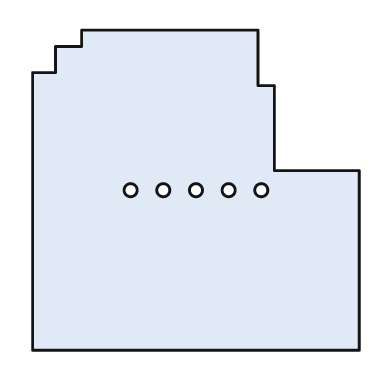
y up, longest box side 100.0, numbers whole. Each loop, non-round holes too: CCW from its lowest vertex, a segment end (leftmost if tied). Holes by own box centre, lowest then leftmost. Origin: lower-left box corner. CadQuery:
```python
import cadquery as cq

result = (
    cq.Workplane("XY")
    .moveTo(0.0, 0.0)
    .lineTo(100.0, 0.0)
    .lineTo(100.0, 55.0)
    .lineTo(74.0, 55.0)
    .lineTo(74.0, 81.0)
    .lineTo(69.0, 81.0)
    .lineTo(69.0, 98.0)
    .lineTo(15.0, 98.0)
    .lineTo(15.0, 93.0)
    .lineTo(7.0, 93.0)
    .lineTo(7.0, 85.0)
    .lineTo(0.0, 85.0)
    .close()
    .moveTo(30.0, 49.0)
    .circle(2.0)
    .moveTo(40.0, 49.0)
    .circle(2.0)
    .moveTo(50.0, 49.0)
    .circle(2.0)
    .moveTo(60.0, 49.0)
    .circle(2.0)
    .moveTo(70.0, 49.0)
    .circle(2.0)
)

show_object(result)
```